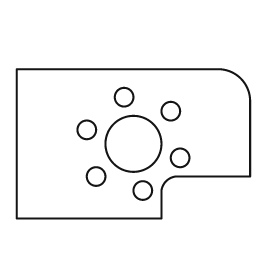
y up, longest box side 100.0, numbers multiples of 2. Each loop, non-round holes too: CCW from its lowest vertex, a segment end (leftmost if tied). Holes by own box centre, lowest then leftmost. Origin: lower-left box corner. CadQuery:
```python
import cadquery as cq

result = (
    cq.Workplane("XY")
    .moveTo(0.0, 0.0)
    .lineTo(62.0, 0.0)
    .lineTo(62.0, 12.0)
    .threePointArc((64.0, 16.0), (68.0, 18.0))
    .lineTo(100.0, 18.0)
    .lineTo(100.0, 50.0)
    .threePointArc((96.0, 60.0), (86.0, 64.0))
    .lineTo(0.0, 64.0)
    .close()
    .moveTo(54.0, 12.0)
    .circle(4.0)
    .moveTo(34.0, 18.0)
    .circle(4.0)
    .moveTo(70.0, 26.0)
    .circle(4.0)
    .moveTo(50.0, 32.0)
    .circle(12.0)
    .moveTo(30.0, 38.0)
    .circle(4.0)
    .moveTo(66.0, 46.0)
    .circle(4.0)
    .moveTo(46.0, 52.0)
    .circle(4.0)
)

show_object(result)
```